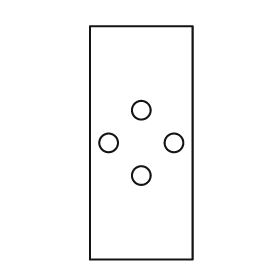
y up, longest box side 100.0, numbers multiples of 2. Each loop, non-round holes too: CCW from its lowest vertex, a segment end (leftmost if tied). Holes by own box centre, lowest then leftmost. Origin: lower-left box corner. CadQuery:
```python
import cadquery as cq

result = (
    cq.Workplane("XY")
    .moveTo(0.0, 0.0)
    .lineTo(44.0, 0.0)
    .lineTo(44.0, 100.0)
    .lineTo(0.0, 100.0)
    .close()
    .moveTo(22.0, 36.0)
    .circle(4.0)
    .moveTo(8.0, 50.0)
    .circle(4.0)
    .moveTo(36.0, 50.0)
    .circle(4.0)
    .moveTo(22.0, 64.0)
    .circle(4.0)
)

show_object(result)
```